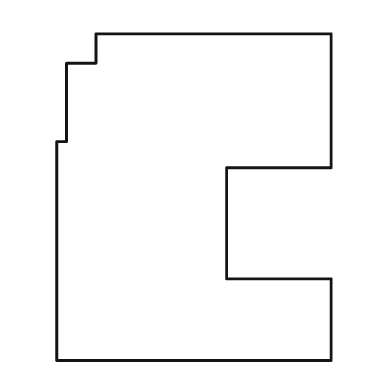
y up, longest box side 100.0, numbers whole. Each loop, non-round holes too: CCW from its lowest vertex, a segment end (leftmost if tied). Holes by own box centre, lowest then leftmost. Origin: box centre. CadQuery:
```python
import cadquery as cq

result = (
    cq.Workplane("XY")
    .moveTo(-42.0, -50.0)
    .lineTo(42.0, -50.0)
    .lineTo(42.0, -25.0)
    .lineTo(10.0, -25.0)
    .lineTo(10.0, 9.0)
    .lineTo(42.0, 9.0)
    .lineTo(42.0, 50.0)
    .lineTo(-30.0, 50.0)
    .lineTo(-30.0, 41.0)
    .lineTo(-39.0, 41.0)
    .lineTo(-39.0, 17.0)
    .lineTo(-42.0, 17.0)
    .close()
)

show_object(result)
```